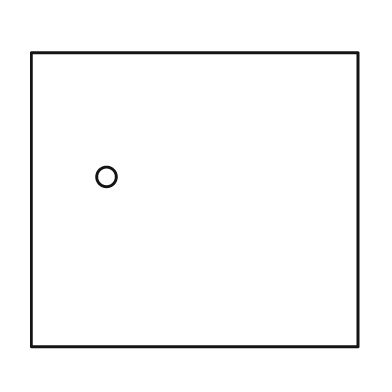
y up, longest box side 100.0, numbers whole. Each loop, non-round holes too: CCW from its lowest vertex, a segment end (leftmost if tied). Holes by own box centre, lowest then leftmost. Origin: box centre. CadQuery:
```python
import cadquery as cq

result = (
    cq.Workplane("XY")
    .moveTo(-50.0, -45.0)
    .lineTo(50.0, -45.0)
    .lineTo(50.0, 45.0)
    .lineTo(-50.0, 45.0)
    .close()
    .moveTo(-27.0, 7.0)
    .circle(3.0)
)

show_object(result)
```